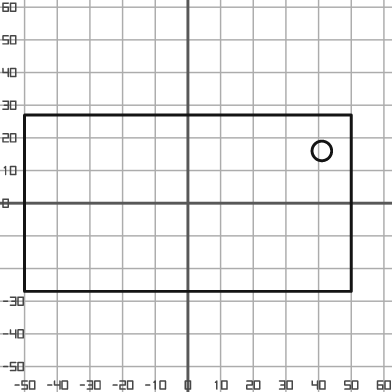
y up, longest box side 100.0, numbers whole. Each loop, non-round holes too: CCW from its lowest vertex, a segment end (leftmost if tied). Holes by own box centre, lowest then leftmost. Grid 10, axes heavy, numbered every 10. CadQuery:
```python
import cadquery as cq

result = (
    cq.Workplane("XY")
    .moveTo(-50.0, -27.0)
    .lineTo(50.0, -27.0)
    .lineTo(50.0, 27.0)
    .lineTo(-50.0, 27.0)
    .close()
    .moveTo(41.0, 16.0)
    .circle(3.0)
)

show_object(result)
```